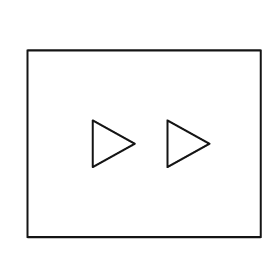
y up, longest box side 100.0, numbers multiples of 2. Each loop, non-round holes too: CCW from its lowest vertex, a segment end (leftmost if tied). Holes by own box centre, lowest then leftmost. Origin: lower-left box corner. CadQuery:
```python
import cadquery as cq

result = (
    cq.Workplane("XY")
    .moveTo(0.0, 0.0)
    .lineTo(100.0, 0.0)
    .lineTo(100.0, 80.0)
    .lineTo(0.0, 80.0)
    .close()
    .moveTo(28.0, 30.0)
    .lineTo(46.0, 40.0)
    .lineTo(28.0, 50.0)
    .close()
    .moveTo(60.0, 30.0)
    .lineTo(78.0, 40.0)
    .lineTo(60.0, 50.0)
    .close()
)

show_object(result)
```